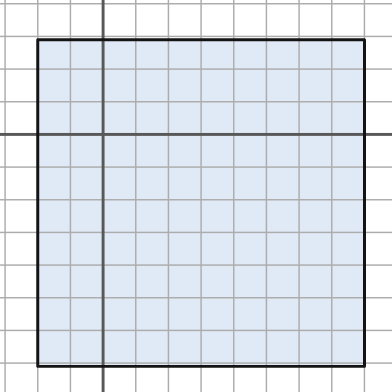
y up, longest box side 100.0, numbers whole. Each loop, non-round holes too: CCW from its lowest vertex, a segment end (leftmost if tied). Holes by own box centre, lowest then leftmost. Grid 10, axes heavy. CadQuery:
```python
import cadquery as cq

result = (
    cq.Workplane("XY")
    .moveTo(-20.0, -71.0)
    .lineTo(80.0, -71.0)
    .lineTo(80.0, 29.0)
    .lineTo(-20.0, 29.0)
    .close()
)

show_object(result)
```